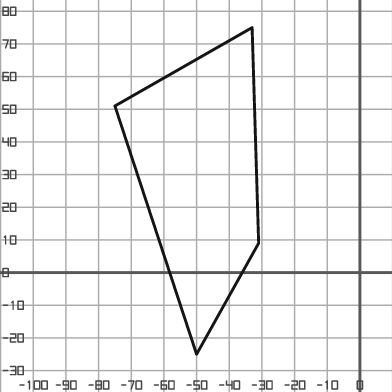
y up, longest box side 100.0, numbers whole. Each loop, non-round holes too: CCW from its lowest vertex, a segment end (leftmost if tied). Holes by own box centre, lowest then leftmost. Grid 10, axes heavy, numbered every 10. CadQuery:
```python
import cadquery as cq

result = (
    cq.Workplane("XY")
    .moveTo(-50.0, -25.0)
    .lineTo(-31.0, 9.0)
    .lineTo(-33.0, 75.0)
    .lineTo(-75.0, 51.0)
    .close()
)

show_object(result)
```